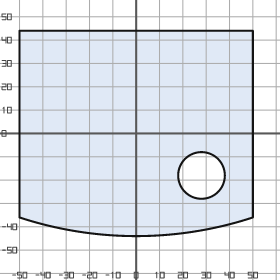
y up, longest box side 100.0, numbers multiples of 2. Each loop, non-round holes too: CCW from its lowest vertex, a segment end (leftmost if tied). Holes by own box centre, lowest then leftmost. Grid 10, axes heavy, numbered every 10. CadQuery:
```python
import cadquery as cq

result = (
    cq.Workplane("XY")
    .moveTo(-50.0, -36.0)
    .threePointArc((0.0, -44.0), (50.0, -36.0))
    .lineTo(50.0, 44.0)
    .lineTo(-50.0, 44.0)
    .close()
    .moveTo(28.0, -18.0)
    .circle(10.0)
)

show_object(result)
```